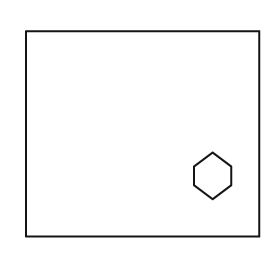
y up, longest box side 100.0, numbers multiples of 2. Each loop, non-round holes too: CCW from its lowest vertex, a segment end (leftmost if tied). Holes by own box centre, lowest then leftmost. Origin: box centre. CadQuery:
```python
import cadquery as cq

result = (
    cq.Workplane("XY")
    .moveTo(-50.0, -44.0)
    .lineTo(50.0, -44.0)
    .lineTo(50.0, 44.0)
    .lineTo(-50.0, 44.0)
    .close()
    .moveTo(30.0, -28.0)
    .lineTo(38.0, -22.0)
    .lineTo(38.0, -14.0)
    .lineTo(30.0, -8.0)
    .lineTo(22.0, -14.0)
    .lineTo(22.0, -22.0)
    .close()
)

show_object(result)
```